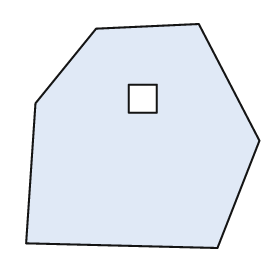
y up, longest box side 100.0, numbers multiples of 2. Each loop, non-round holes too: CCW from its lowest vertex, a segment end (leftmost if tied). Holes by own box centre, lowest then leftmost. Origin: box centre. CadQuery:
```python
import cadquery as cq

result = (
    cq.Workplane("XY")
    .moveTo(32.0, -48.0)
    .lineTo(50.0, -2.0)
    .lineTo(24.0, 48.0)
    .lineTo(-20.0, 46.0)
    .lineTo(-46.0, 14.0)
    .lineTo(-50.0, -46.0)
    .close()
    .moveTo(-6.0, 10.0)
    .lineTo(6.0, 10.0)
    .lineTo(6.0, 22.0)
    .lineTo(-6.0, 22.0)
    .close()
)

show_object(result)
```